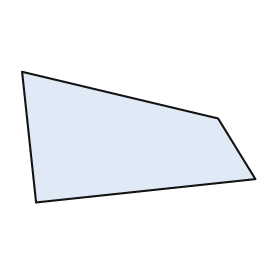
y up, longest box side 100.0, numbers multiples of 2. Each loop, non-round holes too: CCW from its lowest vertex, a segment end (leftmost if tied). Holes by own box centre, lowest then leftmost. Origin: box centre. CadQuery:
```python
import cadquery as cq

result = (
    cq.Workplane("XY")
    .moveTo(-44.0, -28.0)
    .lineTo(50.0, -18.0)
    .lineTo(34.0, 8.0)
    .lineTo(-50.0, 28.0)
    .close()
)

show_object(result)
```